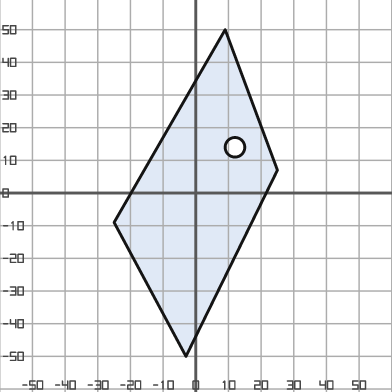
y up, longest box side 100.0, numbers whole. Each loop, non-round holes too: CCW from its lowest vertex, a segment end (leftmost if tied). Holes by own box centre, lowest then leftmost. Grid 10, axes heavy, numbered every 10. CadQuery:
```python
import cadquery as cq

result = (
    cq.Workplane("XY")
    .moveTo(-3.0, -50.0)
    .lineTo(25.0, 7.0)
    .lineTo(9.0, 50.0)
    .lineTo(-25.0, -9.0)
    .close()
    .moveTo(12.0, 14.0)
    .circle(3.0)
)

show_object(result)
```